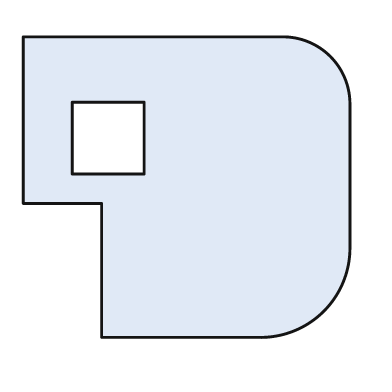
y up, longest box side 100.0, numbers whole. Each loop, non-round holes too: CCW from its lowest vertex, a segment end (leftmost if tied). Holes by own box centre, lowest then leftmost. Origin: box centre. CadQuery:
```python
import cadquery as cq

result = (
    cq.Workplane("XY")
    .moveTo(-26.0, -46.0)
    .lineTo(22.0, -46.0)
    .threePointArc((42.0, -38.0), (50.0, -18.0))
    .lineTo(50.0, 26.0)
    .threePointArc((44.0, 40.0), (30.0, 46.0))
    .lineTo(-50.0, 46.0)
    .lineTo(-50.0, -5.0)
    .lineTo(-26.0, -5.0)
    .close()
    .moveTo(-35.0, 4.0)
    .lineTo(-13.0, 4.0)
    .lineTo(-13.0, 26.0)
    .lineTo(-35.0, 26.0)
    .close()
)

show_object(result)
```